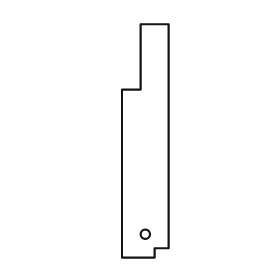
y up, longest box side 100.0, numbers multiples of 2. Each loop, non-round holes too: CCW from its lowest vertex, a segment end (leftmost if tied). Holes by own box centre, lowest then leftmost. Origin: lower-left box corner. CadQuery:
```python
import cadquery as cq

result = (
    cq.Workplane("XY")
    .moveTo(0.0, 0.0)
    .lineTo(14.0, 0.0)
    .lineTo(14.0, 4.0)
    .lineTo(20.0, 4.0)
    .lineTo(20.0, 100.0)
    .lineTo(8.0, 100.0)
    .lineTo(8.0, 72.0)
    .lineTo(0.0, 72.0)
    .close()
    .moveTo(10.0, 10.0)
    .circle(2.0)
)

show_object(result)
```